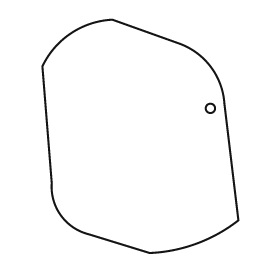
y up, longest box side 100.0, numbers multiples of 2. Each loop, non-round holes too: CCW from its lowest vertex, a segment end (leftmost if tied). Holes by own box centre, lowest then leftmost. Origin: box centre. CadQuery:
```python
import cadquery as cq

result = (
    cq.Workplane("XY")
    .moveTo(4.0, -50.0)
    .threePointArc((24.0, -46.0), (42.0, -36.0))
    .lineTo(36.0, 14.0)
    .threePointArc((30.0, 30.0), (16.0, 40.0))
    .lineTo(-12.0, 50.0)
    .threePointArc((-30.0, 44.0), (-42.0, 30.0))
    .lineTo(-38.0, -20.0)
    .threePointArc((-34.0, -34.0), (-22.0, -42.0))
    .close()
    .moveTo(30.0, 12.0)
    .circle(2.0)
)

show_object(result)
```